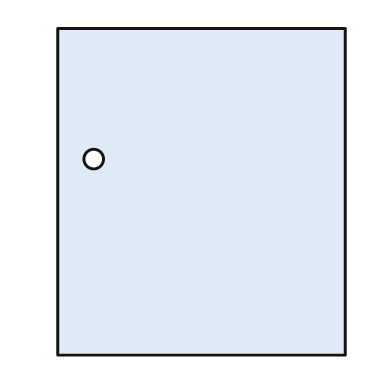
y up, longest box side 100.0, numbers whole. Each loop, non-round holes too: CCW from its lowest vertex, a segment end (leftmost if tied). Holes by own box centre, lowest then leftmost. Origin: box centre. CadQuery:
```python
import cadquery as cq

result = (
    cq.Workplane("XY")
    .moveTo(-44.0, -50.0)
    .lineTo(44.0, -50.0)
    .lineTo(44.0, 50.0)
    .lineTo(-44.0, 50.0)
    .close()
    .moveTo(-33.0, 10.0)
    .circle(3.0)
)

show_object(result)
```